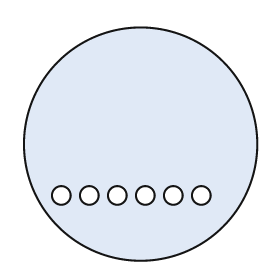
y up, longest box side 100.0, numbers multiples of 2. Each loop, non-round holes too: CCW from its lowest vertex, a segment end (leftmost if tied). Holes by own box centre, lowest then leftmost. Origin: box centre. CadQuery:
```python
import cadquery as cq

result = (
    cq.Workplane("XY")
    .moveTo(0.0, 0.0)
    .circle(50.0)
    .moveTo(-34.0, -22.0)
    .circle(4.0)
    .moveTo(-22.0, -22.0)
    .circle(4.0)
    .moveTo(-10.0, -22.0)
    .circle(4.0)
    .moveTo(2.0, -22.0)
    .circle(4.0)
    .moveTo(14.0, -22.0)
    .circle(4.0)
    .moveTo(26.0, -22.0)
    .circle(4.0)
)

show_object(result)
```